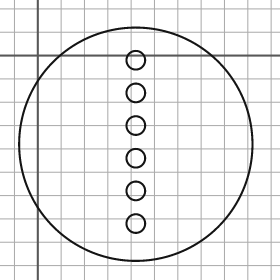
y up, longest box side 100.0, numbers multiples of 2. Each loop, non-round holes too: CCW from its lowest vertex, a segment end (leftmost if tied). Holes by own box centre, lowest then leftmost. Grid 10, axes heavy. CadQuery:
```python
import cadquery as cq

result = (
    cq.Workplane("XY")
    .moveTo(42.0, -38.0)
    .circle(50.0)
    .moveTo(42.0, -72.0)
    .circle(4.0)
    .moveTo(42.0, -58.0)
    .circle(4.0)
    .moveTo(42.0, -44.0)
    .circle(4.0)
    .moveTo(42.0, -30.0)
    .circle(4.0)
    .moveTo(42.0, -16.0)
    .circle(4.0)
    .moveTo(42.0, -2.0)
    .circle(4.0)
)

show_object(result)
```